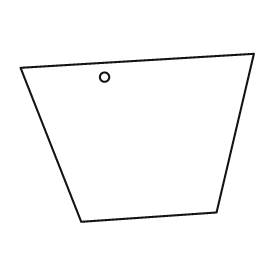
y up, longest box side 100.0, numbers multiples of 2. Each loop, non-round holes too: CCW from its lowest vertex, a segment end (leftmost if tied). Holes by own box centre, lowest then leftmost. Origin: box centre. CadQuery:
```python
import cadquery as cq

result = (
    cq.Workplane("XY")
    .moveTo(-24.0, -36.0)
    .lineTo(34.0, -32.0)
    .lineTo(50.0, 36.0)
    .lineTo(-50.0, 30.0)
    .close()
    .moveTo(-14.0, 26.0)
    .circle(2.0)
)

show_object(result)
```